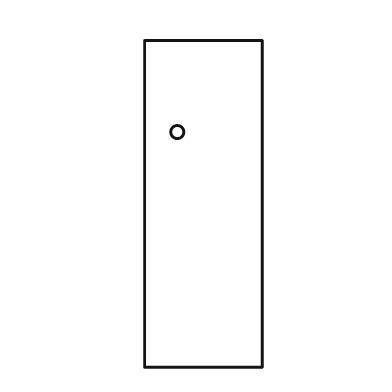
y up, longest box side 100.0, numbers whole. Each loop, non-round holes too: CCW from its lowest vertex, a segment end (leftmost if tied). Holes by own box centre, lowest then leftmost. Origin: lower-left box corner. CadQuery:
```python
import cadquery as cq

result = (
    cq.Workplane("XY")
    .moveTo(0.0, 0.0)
    .lineTo(36.0, 0.0)
    .lineTo(36.0, 100.0)
    .lineTo(0.0, 100.0)
    .close()
    .moveTo(10.0, 72.0)
    .circle(2.0)
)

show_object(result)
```